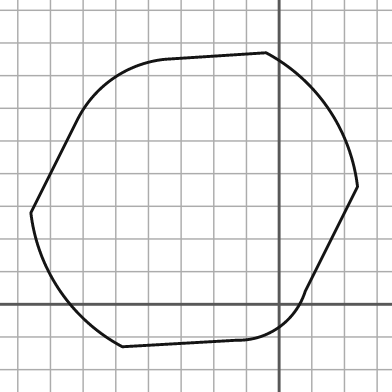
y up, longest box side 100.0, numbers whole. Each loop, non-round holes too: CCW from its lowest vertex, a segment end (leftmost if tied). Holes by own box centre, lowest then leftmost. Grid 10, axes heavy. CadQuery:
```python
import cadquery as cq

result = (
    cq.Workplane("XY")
    .moveTo(-48.0, -13.0)
    .lineTo(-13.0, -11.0)
    .threePointArc((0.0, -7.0), (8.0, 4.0))
    .lineTo(24.0, 36.0)
    .threePointArc((15.0, 60.0), (-4.0, 77.0))
    .lineTo(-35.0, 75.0)
    .threePointArc((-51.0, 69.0), (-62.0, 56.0))
    .lineTo(-76.0, 28.0)
    .threePointArc((-67.0, 4.0), (-48.0, -13.0))
    .close()
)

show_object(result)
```